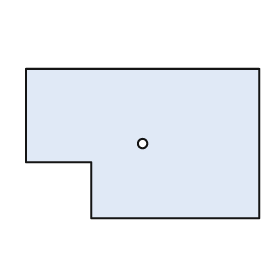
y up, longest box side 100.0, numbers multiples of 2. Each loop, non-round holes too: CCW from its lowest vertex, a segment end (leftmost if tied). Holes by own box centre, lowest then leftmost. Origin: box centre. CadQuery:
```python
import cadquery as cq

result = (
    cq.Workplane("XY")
    .moveTo(-22.0, -32.0)
    .lineTo(50.0, -32.0)
    .lineTo(50.0, 32.0)
    .lineTo(-50.0, 32.0)
    .lineTo(-50.0, -8.0)
    .lineTo(-22.0, -8.0)
    .close()
    .moveTo(0.0, 0.0)
    .circle(2.0)
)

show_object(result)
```